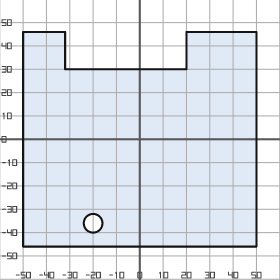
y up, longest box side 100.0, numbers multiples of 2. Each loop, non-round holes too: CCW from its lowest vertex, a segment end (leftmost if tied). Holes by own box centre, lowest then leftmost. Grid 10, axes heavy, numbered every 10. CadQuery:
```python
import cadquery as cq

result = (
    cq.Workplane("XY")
    .moveTo(-50.0, -46.0)
    .lineTo(50.0, -46.0)
    .lineTo(50.0, 46.0)
    .lineTo(20.0, 46.0)
    .lineTo(20.0, 30.0)
    .lineTo(-32.0, 30.0)
    .lineTo(-32.0, 46.0)
    .lineTo(-50.0, 46.0)
    .close()
    .moveTo(-20.0, -36.0)
    .circle(4.0)
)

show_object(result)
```